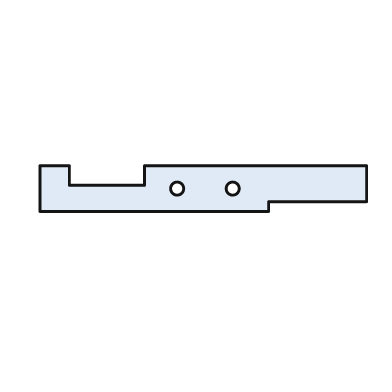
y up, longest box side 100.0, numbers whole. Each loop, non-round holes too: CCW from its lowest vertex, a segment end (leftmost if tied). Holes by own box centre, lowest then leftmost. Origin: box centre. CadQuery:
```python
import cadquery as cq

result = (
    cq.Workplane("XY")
    .moveTo(-50.0, -7.0)
    .lineTo(20.0, -7.0)
    .lineTo(20.0, -4.0)
    .lineTo(50.0, -4.0)
    .lineTo(50.0, 7.0)
    .lineTo(-18.0, 7.0)
    .lineTo(-18.0, 1.0)
    .lineTo(-41.0, 1.0)
    .lineTo(-41.0, 7.0)
    .lineTo(-50.0, 7.0)
    .close()
    .moveTo(-8.0, 0.0)
    .circle(2.0)
    .moveTo(9.0, 0.0)
    .circle(2.0)
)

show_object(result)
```